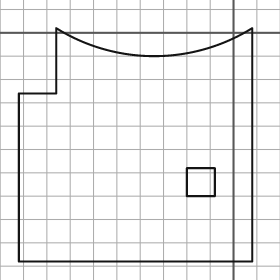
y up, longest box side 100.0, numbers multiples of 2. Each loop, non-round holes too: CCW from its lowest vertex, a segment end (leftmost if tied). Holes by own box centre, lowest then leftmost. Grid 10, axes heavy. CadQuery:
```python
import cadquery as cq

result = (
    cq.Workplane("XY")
    .moveTo(-92.0, -98.0)
    .lineTo(8.0, -98.0)
    .lineTo(8.0, 2.0)
    .threePointArc((-34.0, -10.0), (-76.0, 2.0))
    .lineTo(-76.0, -26.0)
    .lineTo(-92.0, -26.0)
    .close()
    .moveTo(-20.0, -70.0)
    .lineTo(-8.0, -70.0)
    .lineTo(-8.0, -58.0)
    .lineTo(-20.0, -58.0)
    .close()
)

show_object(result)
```